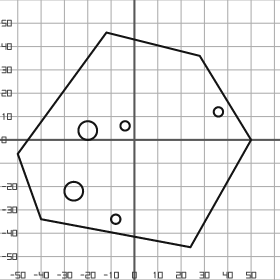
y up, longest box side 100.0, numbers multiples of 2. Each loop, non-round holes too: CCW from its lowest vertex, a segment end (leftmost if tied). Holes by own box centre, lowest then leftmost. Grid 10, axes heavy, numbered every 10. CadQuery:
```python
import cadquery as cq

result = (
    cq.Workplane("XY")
    .moveTo(24.0, -46.0)
    .lineTo(50.0, 0.0)
    .lineTo(28.0, 36.0)
    .lineTo(-12.0, 46.0)
    .lineTo(-50.0, -6.0)
    .lineTo(-40.0, -34.0)
    .close()
    .moveTo(-8.0, -34.0)
    .circle(2.0)
    .moveTo(-26.0, -22.0)
    .circle(4.0)
    .moveTo(-20.0, 4.0)
    .circle(4.0)
    .moveTo(-4.0, 6.0)
    .circle(2.0)
    .moveTo(36.0, 12.0)
    .circle(2.0)
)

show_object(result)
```